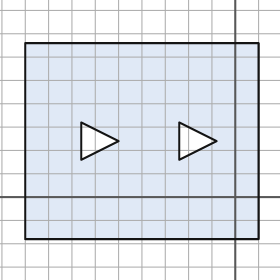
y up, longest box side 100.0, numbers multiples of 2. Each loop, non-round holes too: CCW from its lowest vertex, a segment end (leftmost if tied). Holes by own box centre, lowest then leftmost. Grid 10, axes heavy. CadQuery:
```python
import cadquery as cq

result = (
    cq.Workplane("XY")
    .moveTo(-90.0, -18.0)
    .lineTo(10.0, -18.0)
    .lineTo(10.0, 66.0)
    .lineTo(-90.0, 66.0)
    .close()
    .moveTo(-66.0, 16.0)
    .lineTo(-50.0, 24.0)
    .lineTo(-66.0, 32.0)
    .close()
    .moveTo(-24.0, 16.0)
    .lineTo(-8.0, 24.0)
    .lineTo(-24.0, 32.0)
    .close()
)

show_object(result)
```